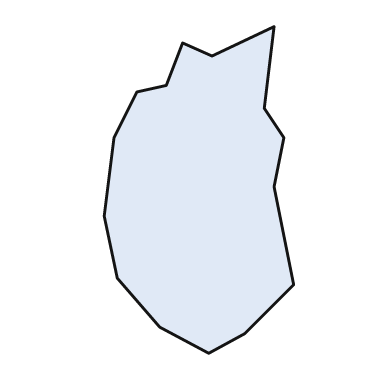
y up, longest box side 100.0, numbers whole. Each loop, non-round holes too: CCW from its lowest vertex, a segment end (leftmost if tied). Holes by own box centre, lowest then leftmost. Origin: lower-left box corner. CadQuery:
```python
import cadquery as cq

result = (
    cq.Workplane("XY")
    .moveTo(32.0, 0.0)
    .lineTo(43.0, 6.0)
    .lineTo(58.0, 21.0)
    .lineTo(52.0, 51.0)
    .lineTo(55.0, 66.0)
    .lineTo(49.0, 75.0)
    .lineTo(52.0, 100.0)
    .lineTo(33.0, 91.0)
    .lineTo(24.0, 95.0)
    .lineTo(19.0, 82.0)
    .lineTo(10.0, 80.0)
    .lineTo(3.0, 66.0)
    .lineTo(0.0, 42.0)
    .lineTo(4.0, 23.0)
    .lineTo(17.0, 8.0)
    .close()
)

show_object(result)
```